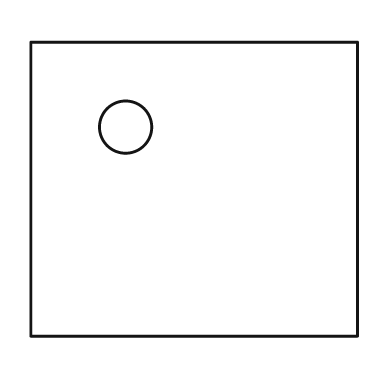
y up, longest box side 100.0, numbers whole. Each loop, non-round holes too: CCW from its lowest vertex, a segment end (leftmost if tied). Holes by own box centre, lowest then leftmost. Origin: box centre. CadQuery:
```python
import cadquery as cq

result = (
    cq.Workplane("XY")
    .moveTo(-50.0, -45.0)
    .lineTo(50.0, -45.0)
    .lineTo(50.0, 45.0)
    .lineTo(-50.0, 45.0)
    .close()
    .moveTo(-21.0, 19.0)
    .circle(8.0)
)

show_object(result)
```